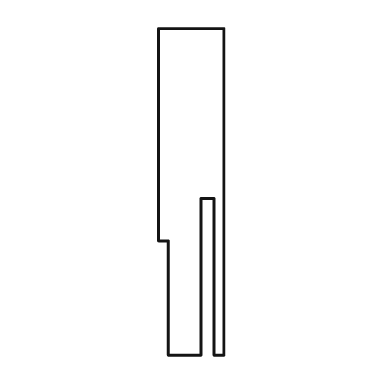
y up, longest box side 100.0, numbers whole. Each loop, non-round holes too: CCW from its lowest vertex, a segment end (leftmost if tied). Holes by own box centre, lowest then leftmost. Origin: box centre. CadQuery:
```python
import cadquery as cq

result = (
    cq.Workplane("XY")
    .moveTo(-7.0, -50.0)
    .lineTo(3.0, -50.0)
    .lineTo(3.0, -2.0)
    .lineTo(7.0, -2.0)
    .lineTo(7.0, -50.0)
    .lineTo(10.0, -50.0)
    .lineTo(10.0, 50.0)
    .lineTo(-10.0, 50.0)
    .lineTo(-10.0, -15.0)
    .lineTo(-7.0, -15.0)
    .close()
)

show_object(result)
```